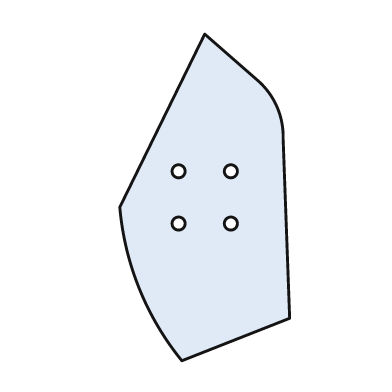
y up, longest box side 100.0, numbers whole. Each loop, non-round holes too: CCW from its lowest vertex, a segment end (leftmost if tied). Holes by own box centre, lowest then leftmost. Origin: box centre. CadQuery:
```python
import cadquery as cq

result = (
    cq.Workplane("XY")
    .moveTo(-7.0, -50.0)
    .lineTo(26.0, -37.0)
    .lineTo(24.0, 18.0)
    .threePointArc((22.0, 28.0), (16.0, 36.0))
    .lineTo(0.0, 50.0)
    .lineTo(-26.0, -3.0)
    .threePointArc((-20.0, -28.0), (-7.0, -50.0))
    .close()
    .moveTo(-8.0, -8.0)
    .circle(2.0)
    .moveTo(8.0, -8.0)
    .circle(2.0)
    .moveTo(-8.0, 8.0)
    .circle(2.0)
    .moveTo(8.0, 8.0)
    .circle(2.0)
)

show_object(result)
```